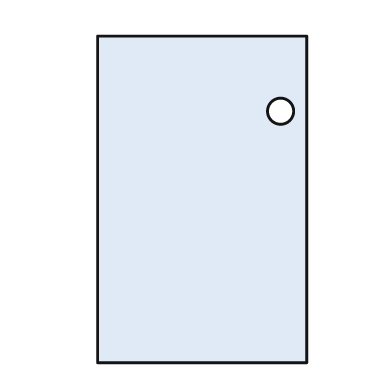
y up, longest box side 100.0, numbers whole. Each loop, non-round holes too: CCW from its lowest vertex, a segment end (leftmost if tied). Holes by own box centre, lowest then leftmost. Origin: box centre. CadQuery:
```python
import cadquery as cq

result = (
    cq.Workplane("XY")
    .moveTo(-32.0, -50.0)
    .lineTo(32.0, -50.0)
    .lineTo(32.0, 50.0)
    .lineTo(-32.0, 50.0)
    .close()
    .moveTo(24.0, 27.0)
    .circle(4.0)
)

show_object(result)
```